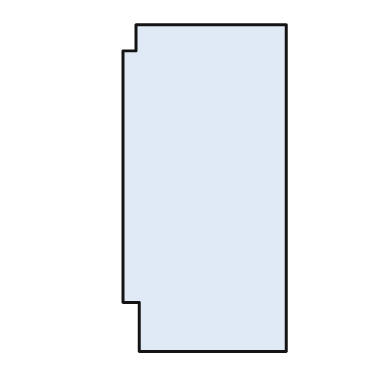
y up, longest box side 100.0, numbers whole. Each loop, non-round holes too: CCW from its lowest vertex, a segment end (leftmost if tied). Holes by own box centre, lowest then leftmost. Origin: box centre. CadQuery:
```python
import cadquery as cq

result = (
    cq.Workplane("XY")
    .moveTo(-20.0, -50.0)
    .lineTo(25.0, -50.0)
    .lineTo(25.0, 50.0)
    .lineTo(-21.0, 50.0)
    .lineTo(-21.0, 42.0)
    .lineTo(-25.0, 42.0)
    .lineTo(-25.0, -35.0)
    .lineTo(-20.0, -35.0)
    .close()
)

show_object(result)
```